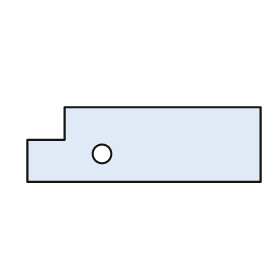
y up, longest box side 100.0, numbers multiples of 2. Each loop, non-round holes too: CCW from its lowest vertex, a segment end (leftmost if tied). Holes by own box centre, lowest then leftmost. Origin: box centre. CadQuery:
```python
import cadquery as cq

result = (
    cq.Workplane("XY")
    .moveTo(-50.0, -16.0)
    .lineTo(50.0, -16.0)
    .lineTo(50.0, 16.0)
    .lineTo(-34.0, 16.0)
    .lineTo(-34.0, 2.0)
    .lineTo(-50.0, 2.0)
    .close()
    .moveTo(-18.0, -4.0)
    .circle(4.0)
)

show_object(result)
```